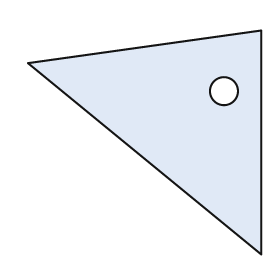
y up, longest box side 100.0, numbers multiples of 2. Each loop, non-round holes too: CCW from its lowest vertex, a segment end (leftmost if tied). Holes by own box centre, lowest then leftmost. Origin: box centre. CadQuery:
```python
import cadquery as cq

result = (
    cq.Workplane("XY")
    .moveTo(50.0, -48.0)
    .lineTo(50.0, 48.0)
    .lineTo(-50.0, 34.0)
    .close()
    .moveTo(34.0, 22.0)
    .circle(6.0)
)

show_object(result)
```